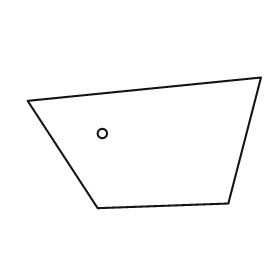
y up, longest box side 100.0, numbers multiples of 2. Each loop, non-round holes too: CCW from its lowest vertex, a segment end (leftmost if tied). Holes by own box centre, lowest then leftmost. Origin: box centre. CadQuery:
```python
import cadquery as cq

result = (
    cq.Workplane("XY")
    .moveTo(-20.0, -28.0)
    .lineTo(36.0, -26.0)
    .lineTo(50.0, 28.0)
    .lineTo(-50.0, 18.0)
    .close()
    .moveTo(-18.0, 4.0)
    .circle(2.0)
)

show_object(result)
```